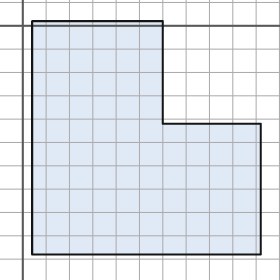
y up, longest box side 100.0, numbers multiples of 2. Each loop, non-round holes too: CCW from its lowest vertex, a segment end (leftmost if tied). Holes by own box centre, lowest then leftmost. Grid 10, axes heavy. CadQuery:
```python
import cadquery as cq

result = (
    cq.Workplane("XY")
    .moveTo(4.0, -98.0)
    .lineTo(102.0, -98.0)
    .lineTo(102.0, -42.0)
    .lineTo(60.0, -42.0)
    .lineTo(60.0, 2.0)
    .lineTo(4.0, 2.0)
    .close()
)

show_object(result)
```